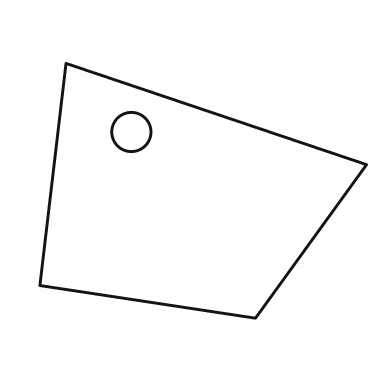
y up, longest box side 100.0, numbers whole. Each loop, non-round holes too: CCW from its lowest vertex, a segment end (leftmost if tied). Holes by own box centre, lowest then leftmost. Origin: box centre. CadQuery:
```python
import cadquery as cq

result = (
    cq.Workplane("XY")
    .moveTo(16.0, -39.0)
    .lineTo(50.0, 8.0)
    .lineTo(-42.0, 39.0)
    .lineTo(-50.0, -29.0)
    .close()
    .moveTo(-22.0, 18.0)
    .circle(6.0)
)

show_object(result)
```